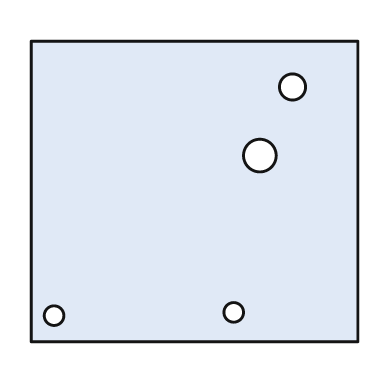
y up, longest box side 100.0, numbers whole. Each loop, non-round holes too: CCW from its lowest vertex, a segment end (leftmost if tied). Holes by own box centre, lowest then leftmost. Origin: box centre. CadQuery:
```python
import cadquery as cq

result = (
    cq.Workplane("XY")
    .moveTo(-50.0, -46.0)
    .lineTo(50.0, -46.0)
    .lineTo(50.0, 46.0)
    .lineTo(-50.0, 46.0)
    .close()
    .moveTo(-43.0, -38.0)
    .circle(3.0)
    .moveTo(12.0, -37.0)
    .circle(3.0)
    .moveTo(20.0, 11.0)
    .circle(5.0)
    .moveTo(30.0, 32.0)
    .circle(4.0)
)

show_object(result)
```